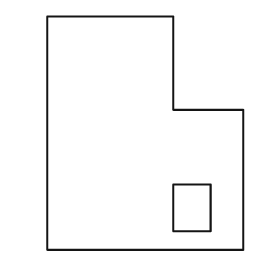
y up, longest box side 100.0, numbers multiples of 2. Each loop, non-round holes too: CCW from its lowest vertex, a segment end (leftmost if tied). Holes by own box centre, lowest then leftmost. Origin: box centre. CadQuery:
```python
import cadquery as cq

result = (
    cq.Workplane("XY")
    .moveTo(-42.0, -50.0)
    .lineTo(42.0, -50.0)
    .lineTo(42.0, 10.0)
    .lineTo(12.0, 10.0)
    .lineTo(12.0, 50.0)
    .lineTo(-42.0, 50.0)
    .close()
    .moveTo(12.0, -42.0)
    .lineTo(28.0, -42.0)
    .lineTo(28.0, -22.0)
    .lineTo(12.0, -22.0)
    .close()
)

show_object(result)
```